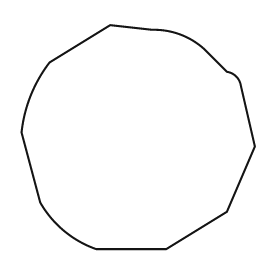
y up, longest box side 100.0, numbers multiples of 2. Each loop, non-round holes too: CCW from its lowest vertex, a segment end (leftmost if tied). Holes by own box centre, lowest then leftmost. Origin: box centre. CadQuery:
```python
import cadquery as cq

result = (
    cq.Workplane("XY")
    .moveTo(-18.0, -48.0)
    .lineTo(12.0, -48.0)
    .lineTo(38.0, -32.0)
    .lineTo(50.0, -4.0)
    .lineTo(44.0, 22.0)
    .threePointArc((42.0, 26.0), (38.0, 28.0))
    .lineTo(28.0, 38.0)
    .threePointArc((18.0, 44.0), (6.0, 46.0))
    .lineTo(-12.0, 48.0)
    .lineTo(-38.0, 32.0)
    .threePointArc((-46.0, 18.0), (-50.0, 2.0))
    .lineTo(-42.0, -28.0)
    .threePointArc((-32.0, -40.0), (-18.0, -48.0))
    .close()
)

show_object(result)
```